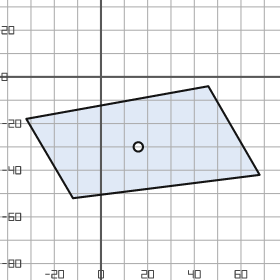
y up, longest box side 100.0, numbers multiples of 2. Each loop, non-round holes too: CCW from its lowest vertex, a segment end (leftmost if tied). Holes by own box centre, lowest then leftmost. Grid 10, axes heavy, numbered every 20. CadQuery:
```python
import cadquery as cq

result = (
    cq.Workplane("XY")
    .moveTo(-12.0, -52.0)
    .lineTo(68.0, -42.0)
    .lineTo(46.0, -4.0)
    .lineTo(-32.0, -18.0)
    .close()
    .moveTo(16.0, -30.0)
    .circle(2.0)
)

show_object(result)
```